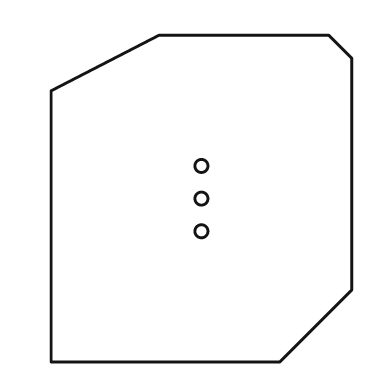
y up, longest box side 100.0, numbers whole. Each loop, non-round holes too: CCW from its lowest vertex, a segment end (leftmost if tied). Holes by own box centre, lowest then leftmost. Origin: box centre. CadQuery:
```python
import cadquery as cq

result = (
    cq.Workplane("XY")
    .moveTo(-46.0, -50.0)
    .lineTo(24.0, -50.0)
    .lineTo(46.0, -28.0)
    .lineTo(46.0, 43.0)
    .lineTo(39.0, 50.0)
    .lineTo(-13.0, 50.0)
    .lineTo(-46.0, 33.0)
    .close()
    .moveTo(0.0, -10.0)
    .circle(2.0)
    .moveTo(0.0, 0.0)
    .circle(2.0)
    .moveTo(0.0, 10.0)
    .circle(2.0)
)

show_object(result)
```